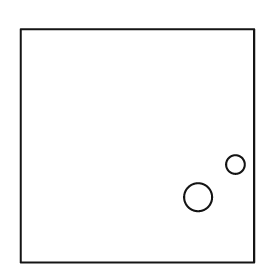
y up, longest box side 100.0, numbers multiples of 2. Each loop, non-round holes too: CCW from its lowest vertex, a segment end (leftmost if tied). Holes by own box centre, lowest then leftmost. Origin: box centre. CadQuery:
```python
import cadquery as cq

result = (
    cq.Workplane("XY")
    .moveTo(-50.0, -50.0)
    .lineTo(50.0, -50.0)
    .lineTo(50.0, 50.0)
    .lineTo(-50.0, 50.0)
    .close()
    .moveTo(26.0, -22.0)
    .circle(6.0)
    .moveTo(42.0, -8.0)
    .circle(4.0)
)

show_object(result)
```